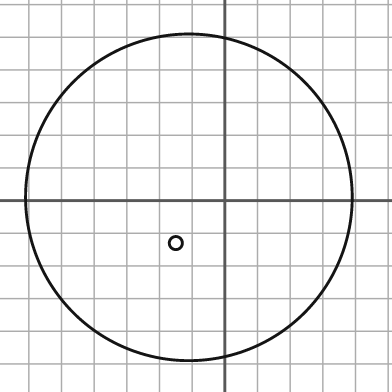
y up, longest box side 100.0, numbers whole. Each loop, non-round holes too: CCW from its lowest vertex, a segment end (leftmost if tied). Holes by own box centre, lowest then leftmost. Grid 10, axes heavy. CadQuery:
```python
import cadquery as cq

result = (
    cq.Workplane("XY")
    .moveTo(-11.0, 1.0)
    .circle(50.0)
    .moveTo(-15.0, -13.0)
    .circle(2.0)
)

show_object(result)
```